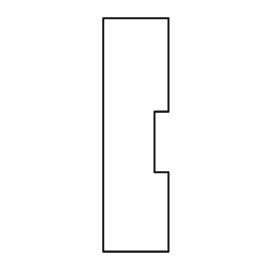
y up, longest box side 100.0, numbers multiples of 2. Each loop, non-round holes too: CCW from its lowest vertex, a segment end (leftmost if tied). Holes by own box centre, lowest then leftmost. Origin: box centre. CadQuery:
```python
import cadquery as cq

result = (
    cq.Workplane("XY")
    .moveTo(-14.0, -50.0)
    .lineTo(14.0, -50.0)
    .lineTo(14.0, -16.0)
    .lineTo(8.0, -16.0)
    .lineTo(8.0, 10.0)
    .lineTo(14.0, 10.0)
    .lineTo(14.0, 50.0)
    .lineTo(-14.0, 50.0)
    .close()
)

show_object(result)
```